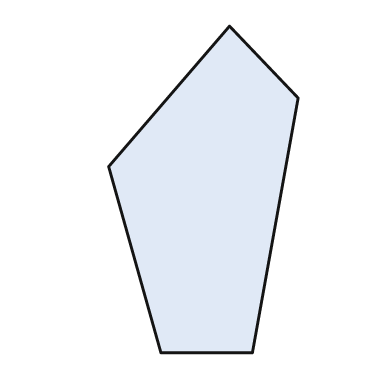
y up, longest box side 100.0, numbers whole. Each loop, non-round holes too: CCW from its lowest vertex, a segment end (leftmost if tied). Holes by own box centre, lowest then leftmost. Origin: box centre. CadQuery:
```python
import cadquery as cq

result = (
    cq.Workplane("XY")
    .moveTo(-13.0, -50.0)
    .lineTo(15.0, -50.0)
    .lineTo(29.0, 28.0)
    .lineTo(8.0, 50.0)
    .lineTo(-29.0, 7.0)
    .close()
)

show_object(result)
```